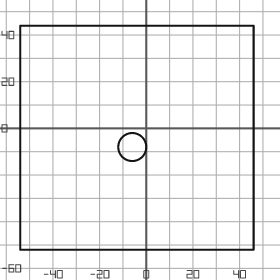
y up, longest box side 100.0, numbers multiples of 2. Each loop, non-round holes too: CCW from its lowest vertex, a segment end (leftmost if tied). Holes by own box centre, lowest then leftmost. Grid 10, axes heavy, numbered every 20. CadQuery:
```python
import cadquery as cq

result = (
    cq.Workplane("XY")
    .moveTo(-54.0, -52.0)
    .lineTo(46.0, -52.0)
    .lineTo(46.0, 44.0)
    .lineTo(-54.0, 44.0)
    .close()
    .moveTo(-6.0, -8.0)
    .circle(6.0)
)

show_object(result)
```